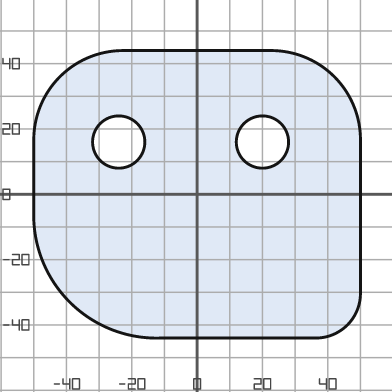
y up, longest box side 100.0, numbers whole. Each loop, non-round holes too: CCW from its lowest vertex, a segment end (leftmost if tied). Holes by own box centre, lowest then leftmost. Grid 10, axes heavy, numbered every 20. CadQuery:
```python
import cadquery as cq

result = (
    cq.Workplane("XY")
    .moveTo(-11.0, -44.0)
    .lineTo(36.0, -44.0)
    .threePointArc((46.0, -40.0), (50.0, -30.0))
    .lineTo(50.0, 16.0)
    .threePointArc((42.0, 36.0), (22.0, 44.0))
    .lineTo(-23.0, 44.0)
    .threePointArc((-42.0, 36.0), (-50.0, 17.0))
    .lineTo(-50.0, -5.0)
    .threePointArc((-39.0, -33.0), (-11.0, -44.0))
    .close()
    .moveTo(-24.0, 16.0)
    .circle(8.0)
    .moveTo(20.0, 16.0)
    .circle(8.0)
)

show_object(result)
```